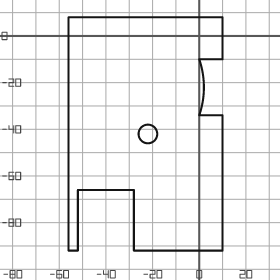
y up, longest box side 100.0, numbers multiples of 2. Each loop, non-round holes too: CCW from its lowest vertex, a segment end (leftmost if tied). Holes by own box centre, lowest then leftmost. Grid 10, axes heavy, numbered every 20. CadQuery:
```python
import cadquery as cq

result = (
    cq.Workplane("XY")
    .moveTo(-56.0, -92.0)
    .lineTo(-52.0, -92.0)
    .lineTo(-52.0, -66.0)
    .lineTo(-28.0, -66.0)
    .lineTo(-28.0, -92.0)
    .lineTo(10.0, -92.0)
    .lineTo(10.0, -34.0)
    .lineTo(0.0, -34.0)
    .threePointArc((2.0, -22.0), (0.0, -10.0))
    .lineTo(10.0, -10.0)
    .lineTo(10.0, 8.0)
    .lineTo(-56.0, 8.0)
    .close()
    .moveTo(-22.0, -42.0)
    .circle(4.0)
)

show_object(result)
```